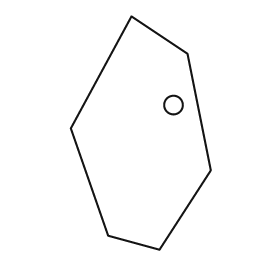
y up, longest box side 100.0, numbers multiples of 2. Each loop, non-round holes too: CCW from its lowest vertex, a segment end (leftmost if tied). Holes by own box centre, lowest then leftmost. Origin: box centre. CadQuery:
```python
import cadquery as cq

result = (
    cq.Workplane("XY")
    .moveTo(8.0, -50.0)
    .lineTo(30.0, -16.0)
    .lineTo(20.0, 34.0)
    .lineTo(-4.0, 50.0)
    .lineTo(-30.0, 2.0)
    .lineTo(-14.0, -44.0)
    .close()
    .moveTo(14.0, 12.0)
    .circle(4.0)
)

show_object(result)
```